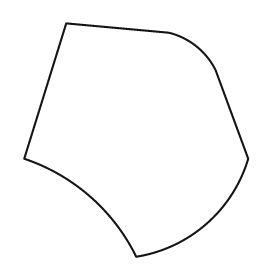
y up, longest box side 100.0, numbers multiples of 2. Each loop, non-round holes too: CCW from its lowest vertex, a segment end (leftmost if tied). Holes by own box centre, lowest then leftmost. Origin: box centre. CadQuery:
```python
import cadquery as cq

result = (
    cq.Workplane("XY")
    .moveTo(0.0, -50.0)
    .threePointArc((30.0, -36.0), (48.0, -8.0))
    .lineTo(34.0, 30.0)
    .threePointArc((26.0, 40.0), (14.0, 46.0))
    .lineTo(-30.0, 50.0)
    .lineTo(-48.0, -8.0)
    .threePointArc((-20.0, -24.0), (0.0, -50.0))
    .close()
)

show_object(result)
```